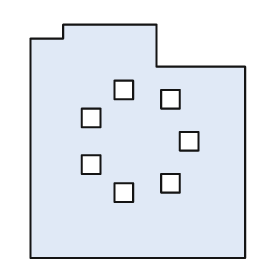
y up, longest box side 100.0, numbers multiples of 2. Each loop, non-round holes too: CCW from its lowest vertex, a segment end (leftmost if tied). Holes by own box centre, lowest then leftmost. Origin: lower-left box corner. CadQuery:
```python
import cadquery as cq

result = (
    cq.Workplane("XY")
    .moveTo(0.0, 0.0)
    .lineTo(92.0, 0.0)
    .lineTo(92.0, 82.0)
    .lineTo(54.0, 82.0)
    .lineTo(54.0, 100.0)
    .lineTo(14.0, 100.0)
    .lineTo(14.0, 94.0)
    .lineTo(0.0, 94.0)
    .close()
    .moveTo(36.0, 24.0)
    .lineTo(44.0, 24.0)
    .lineTo(44.0, 32.0)
    .lineTo(36.0, 32.0)
    .close()
    .moveTo(56.0, 28.0)
    .lineTo(64.0, 28.0)
    .lineTo(64.0, 36.0)
    .lineTo(56.0, 36.0)
    .close()
    .moveTo(22.0, 36.0)
    .lineTo(30.0, 36.0)
    .lineTo(30.0, 44.0)
    .lineTo(22.0, 44.0)
    .close()
    .moveTo(64.0, 46.0)
    .lineTo(72.0, 46.0)
    .lineTo(72.0, 54.0)
    .lineTo(64.0, 54.0)
    .close()
    .moveTo(22.0, 56.0)
    .lineTo(30.0, 56.0)
    .lineTo(30.0, 64.0)
    .lineTo(22.0, 64.0)
    .close()
    .moveTo(56.0, 64.0)
    .lineTo(64.0, 64.0)
    .lineTo(64.0, 72.0)
    .lineTo(56.0, 72.0)
    .close()
    .moveTo(36.0, 68.0)
    .lineTo(44.0, 68.0)
    .lineTo(44.0, 76.0)
    .lineTo(36.0, 76.0)
    .close()
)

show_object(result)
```